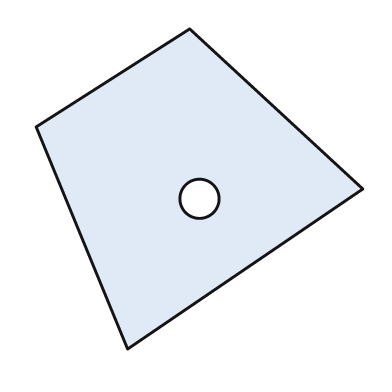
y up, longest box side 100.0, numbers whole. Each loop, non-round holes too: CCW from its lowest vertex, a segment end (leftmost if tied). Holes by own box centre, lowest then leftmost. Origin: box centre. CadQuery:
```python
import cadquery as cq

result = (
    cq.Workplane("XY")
    .moveTo(-22.0, -49.0)
    .lineTo(50.0, 0.0)
    .lineTo(-3.0, 49.0)
    .lineTo(-50.0, 19.0)
    .close()
    .moveTo(0.0, -3.0)
    .circle(6.0)
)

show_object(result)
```